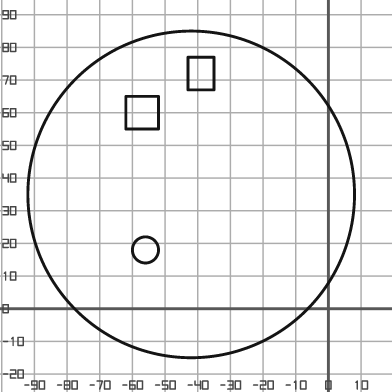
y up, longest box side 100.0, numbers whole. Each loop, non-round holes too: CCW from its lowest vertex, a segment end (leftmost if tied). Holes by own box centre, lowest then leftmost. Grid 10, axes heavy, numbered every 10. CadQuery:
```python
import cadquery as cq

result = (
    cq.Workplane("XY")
    .moveTo(-42.0, 35.0)
    .circle(50.0)
    .moveTo(-56.0, 18.0)
    .circle(4.0)
    .moveTo(-62.0, 55.0)
    .lineTo(-52.0, 55.0)
    .lineTo(-52.0, 65.0)
    .lineTo(-62.0, 65.0)
    .close()
    .moveTo(-43.0, 67.0)
    .lineTo(-35.0, 67.0)
    .lineTo(-35.0, 77.0)
    .lineTo(-43.0, 77.0)
    .close()
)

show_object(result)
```